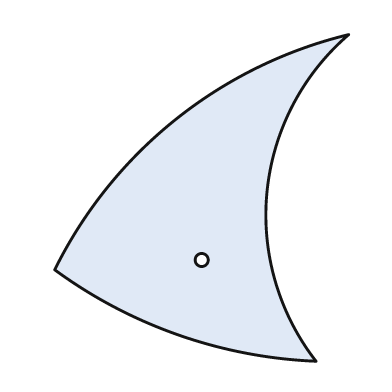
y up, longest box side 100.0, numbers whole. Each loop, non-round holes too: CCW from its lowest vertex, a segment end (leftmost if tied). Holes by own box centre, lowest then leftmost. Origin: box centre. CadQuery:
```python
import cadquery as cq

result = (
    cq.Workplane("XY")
    .moveTo(35.0, -50.0)
    .threePointArc((20.0, 2.0), (45.0, 50.0))
    .threePointArc((-8.0, 24.0), (-45.0, -22.0))
    .threePointArc((-7.0, -42.0), (35.0, -50.0))
    .close()
    .moveTo(0.0, -19.0)
    .circle(2.0)
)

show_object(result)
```